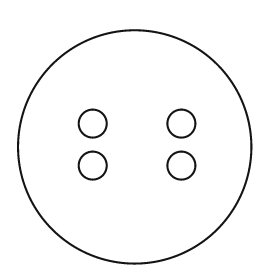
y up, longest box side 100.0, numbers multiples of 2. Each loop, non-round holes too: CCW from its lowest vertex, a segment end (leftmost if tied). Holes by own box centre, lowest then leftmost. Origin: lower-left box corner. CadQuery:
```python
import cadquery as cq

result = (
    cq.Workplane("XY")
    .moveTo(50.0, 50.0)
    .circle(50.0)
    .moveTo(32.0, 42.0)
    .circle(6.0)
    .moveTo(70.0, 42.0)
    .circle(6.0)
    .moveTo(32.0, 60.0)
    .circle(6.0)
    .moveTo(70.0, 60.0)
    .circle(6.0)
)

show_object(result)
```